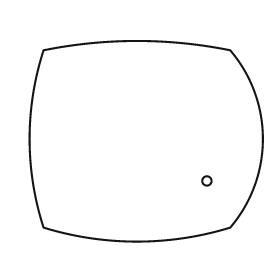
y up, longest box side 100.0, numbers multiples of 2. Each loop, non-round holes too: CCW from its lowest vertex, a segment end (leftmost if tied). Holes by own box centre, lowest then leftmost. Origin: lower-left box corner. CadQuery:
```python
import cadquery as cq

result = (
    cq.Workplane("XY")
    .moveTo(6.0, 6.0)
    .threePointArc((46.0, 0.0), (86.0, 6.0))
    .threePointArc((100.0, 44.0), (86.0, 82.0))
    .threePointArc((46.0, 86.0), (6.0, 82.0))
    .threePointArc((0.0, 44.0), (6.0, 6.0))
    .close()
    .moveTo(76.0, 26.0)
    .circle(2.0)
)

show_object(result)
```